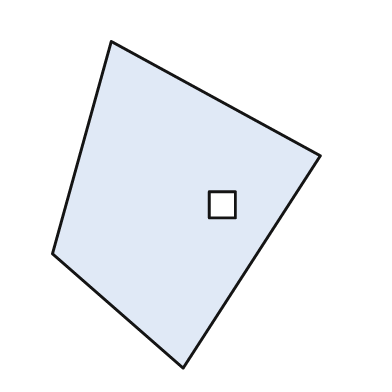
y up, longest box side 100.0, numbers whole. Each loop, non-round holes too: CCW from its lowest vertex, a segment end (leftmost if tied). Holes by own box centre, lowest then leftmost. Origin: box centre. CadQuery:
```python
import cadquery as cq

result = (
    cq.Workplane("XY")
    .moveTo(-1.0, -50.0)
    .lineTo(41.0, 15.0)
    .lineTo(-23.0, 50.0)
    .lineTo(-41.0, -15.0)
    .close()
    .moveTo(7.0, -4.0)
    .lineTo(15.0, -4.0)
    .lineTo(15.0, 4.0)
    .lineTo(7.0, 4.0)
    .close()
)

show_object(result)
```